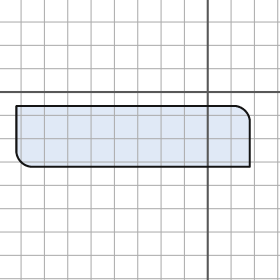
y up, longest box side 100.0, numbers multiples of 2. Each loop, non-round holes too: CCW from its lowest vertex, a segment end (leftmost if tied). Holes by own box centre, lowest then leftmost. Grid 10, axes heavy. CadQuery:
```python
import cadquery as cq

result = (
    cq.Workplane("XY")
    .moveTo(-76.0, -32.0)
    .lineTo(18.0, -32.0)
    .lineTo(18.0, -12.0)
    .threePointArc((16.0, -8.0), (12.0, -6.0))
    .lineTo(-82.0, -6.0)
    .lineTo(-82.0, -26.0)
    .threePointArc((-80.0, -30.0), (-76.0, -32.0))
    .close()
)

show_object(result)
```